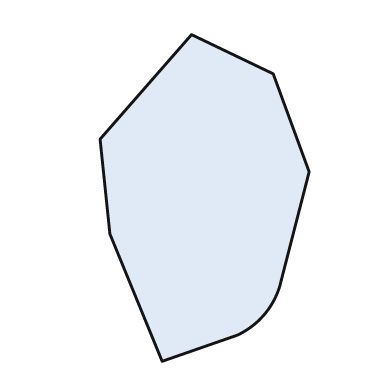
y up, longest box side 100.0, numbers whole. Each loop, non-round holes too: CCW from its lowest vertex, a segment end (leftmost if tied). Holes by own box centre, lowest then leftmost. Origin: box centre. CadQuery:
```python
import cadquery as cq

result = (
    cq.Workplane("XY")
    .moveTo(-13.0, -50.0)
    .lineTo(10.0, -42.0)
    .threePointArc((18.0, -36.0), (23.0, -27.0))
    .lineTo(32.0, 8.0)
    .lineTo(21.0, 38.0)
    .lineTo(-4.0, 50.0)
    .lineTo(-32.0, 18.0)
    .lineTo(-29.0, -11.0)
    .close()
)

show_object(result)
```